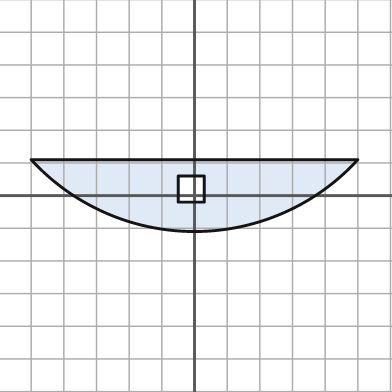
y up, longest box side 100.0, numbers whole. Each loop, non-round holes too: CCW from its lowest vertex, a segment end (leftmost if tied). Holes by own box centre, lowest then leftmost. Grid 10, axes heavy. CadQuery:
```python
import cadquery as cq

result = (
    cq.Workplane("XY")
    .moveTo(-50.0, 11.0)
    .threePointArc((0.0, -11.0), (50.0, 11.0))
    .close()
    .moveTo(-5.0, -2.0)
    .lineTo(3.0, -2.0)
    .lineTo(3.0, 6.0)
    .lineTo(-5.0, 6.0)
    .close()
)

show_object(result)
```